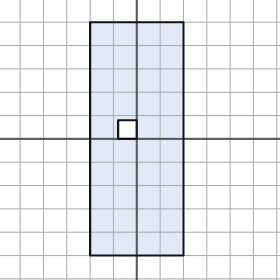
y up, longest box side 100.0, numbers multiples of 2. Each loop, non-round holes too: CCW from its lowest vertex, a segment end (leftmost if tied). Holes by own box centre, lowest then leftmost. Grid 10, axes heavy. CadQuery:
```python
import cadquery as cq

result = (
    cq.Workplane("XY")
    .moveTo(-20.0, -50.0)
    .lineTo(20.0, -50.0)
    .lineTo(20.0, 50.0)
    .lineTo(-20.0, 50.0)
    .close()
    .moveTo(-8.0, 0.0)
    .lineTo(0.0, 0.0)
    .lineTo(0.0, 8.0)
    .lineTo(-8.0, 8.0)
    .close()
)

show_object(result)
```